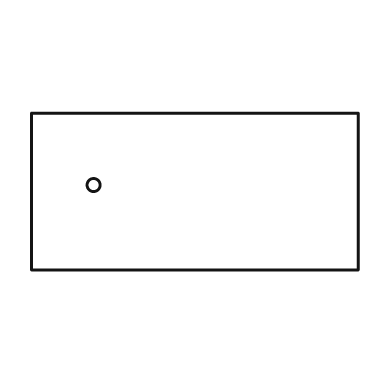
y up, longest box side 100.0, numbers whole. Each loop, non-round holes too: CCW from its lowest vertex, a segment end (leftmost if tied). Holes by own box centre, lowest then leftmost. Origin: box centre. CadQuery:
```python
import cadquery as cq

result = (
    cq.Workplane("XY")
    .moveTo(-50.0, -24.0)
    .lineTo(50.0, -24.0)
    .lineTo(50.0, 24.0)
    .lineTo(-50.0, 24.0)
    .close()
    .moveTo(-31.0, 2.0)
    .circle(2.0)
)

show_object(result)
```